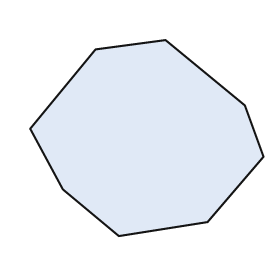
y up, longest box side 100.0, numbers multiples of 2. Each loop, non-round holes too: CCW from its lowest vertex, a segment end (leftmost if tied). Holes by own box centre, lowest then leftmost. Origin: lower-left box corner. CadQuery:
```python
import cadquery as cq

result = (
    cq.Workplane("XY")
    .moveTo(38.0, 0.0)
    .lineTo(76.0, 6.0)
    .lineTo(100.0, 34.0)
    .lineTo(92.0, 56.0)
    .lineTo(58.0, 84.0)
    .lineTo(28.0, 80.0)
    .lineTo(0.0, 46.0)
    .lineTo(14.0, 20.0)
    .close()
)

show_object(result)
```